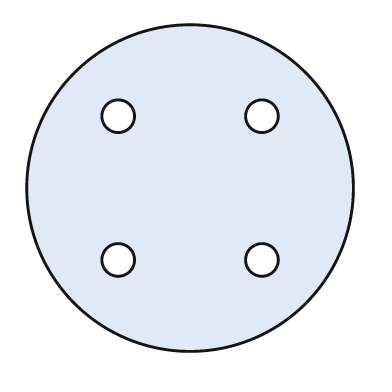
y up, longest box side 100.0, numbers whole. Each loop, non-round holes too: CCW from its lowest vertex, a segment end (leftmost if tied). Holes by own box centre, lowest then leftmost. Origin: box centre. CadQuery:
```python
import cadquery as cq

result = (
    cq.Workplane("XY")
    .moveTo(0.0, 0.0)
    .circle(50.0)
    .moveTo(-22.0, -22.0)
    .circle(5.0)
    .moveTo(22.0, -22.0)
    .circle(5.0)
    .moveTo(-22.0, 22.0)
    .circle(5.0)
    .moveTo(22.0, 22.0)
    .circle(5.0)
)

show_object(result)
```